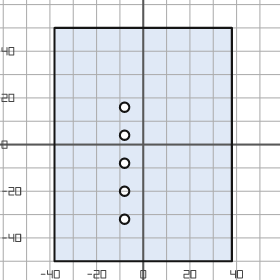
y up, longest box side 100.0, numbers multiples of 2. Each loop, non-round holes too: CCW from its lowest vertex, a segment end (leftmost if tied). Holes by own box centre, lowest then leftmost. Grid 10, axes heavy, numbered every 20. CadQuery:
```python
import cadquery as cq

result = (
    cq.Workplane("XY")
    .moveTo(-38.0, -50.0)
    .lineTo(38.0, -50.0)
    .lineTo(38.0, 50.0)
    .lineTo(-38.0, 50.0)
    .close()
    .moveTo(-8.0, -32.0)
    .circle(2.0)
    .moveTo(-8.0, -20.0)
    .circle(2.0)
    .moveTo(-8.0, -8.0)
    .circle(2.0)
    .moveTo(-8.0, 4.0)
    .circle(2.0)
    .moveTo(-8.0, 16.0)
    .circle(2.0)
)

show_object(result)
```